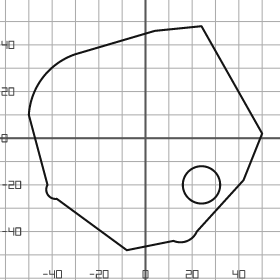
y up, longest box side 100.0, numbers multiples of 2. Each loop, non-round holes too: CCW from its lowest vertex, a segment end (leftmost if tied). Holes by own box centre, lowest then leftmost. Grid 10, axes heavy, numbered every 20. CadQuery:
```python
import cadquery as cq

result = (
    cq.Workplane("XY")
    .moveTo(-8.0, -48.0)
    .lineTo(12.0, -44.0)
    .threePointArc((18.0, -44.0), (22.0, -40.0))
    .lineTo(42.0, -18.0)
    .lineTo(50.0, 2.0)
    .lineTo(24.0, 48.0)
    .lineTo(4.0, 46.0)
    .lineTo(-30.0, 36.0)
    .threePointArc((-44.0, 26.0), (-50.0, 10.0))
    .lineTo(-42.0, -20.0)
    .threePointArc((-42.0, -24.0), (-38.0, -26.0))
    .close()
    .moveTo(24.0, -20.0)
    .circle(8.0)
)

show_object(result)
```